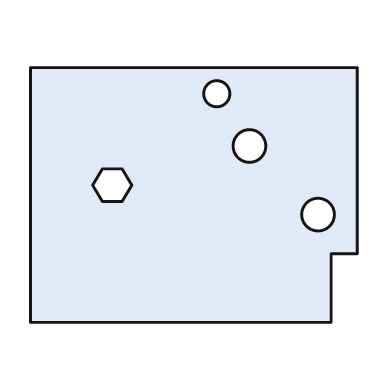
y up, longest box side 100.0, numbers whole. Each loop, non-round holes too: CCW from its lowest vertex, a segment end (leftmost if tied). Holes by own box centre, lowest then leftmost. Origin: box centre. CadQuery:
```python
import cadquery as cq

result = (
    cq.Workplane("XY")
    .moveTo(-50.0, -39.0)
    .lineTo(42.0, -39.0)
    .lineTo(42.0, -18.0)
    .lineTo(50.0, -18.0)
    .lineTo(50.0, 39.0)
    .lineTo(-50.0, 39.0)
    .close()
    .moveTo(38.0, -6.0)
    .circle(5.0)
    .moveTo(-28.0, -2.0)
    .lineTo(-22.0, -2.0)
    .lineTo(-19.0, 3.0)
    .lineTo(-22.0, 8.0)
    .lineTo(-28.0, 8.0)
    .lineTo(-31.0, 3.0)
    .close()
    .moveTo(17.0, 15.0)
    .circle(5.0)
    .moveTo(7.0, 31.0)
    .circle(4.0)
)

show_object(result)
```